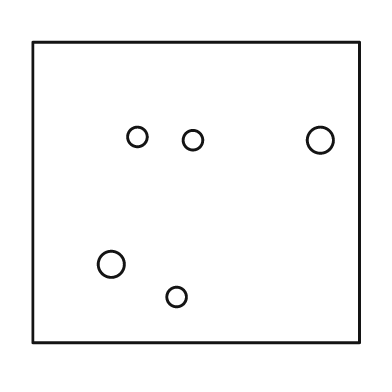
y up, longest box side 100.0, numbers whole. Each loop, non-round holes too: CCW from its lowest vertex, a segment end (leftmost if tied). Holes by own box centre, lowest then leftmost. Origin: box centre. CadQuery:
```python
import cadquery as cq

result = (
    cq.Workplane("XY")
    .moveTo(-50.0, -46.0)
    .lineTo(50.0, -46.0)
    .lineTo(50.0, 46.0)
    .lineTo(-50.0, 46.0)
    .close()
    .moveTo(-6.0, -32.0)
    .circle(3.0)
    .moveTo(-26.0, -22.0)
    .circle(4.0)
    .moveTo(-1.0, 16.0)
    .circle(3.0)
    .moveTo(38.0, 16.0)
    .circle(4.0)
    .moveTo(-18.0, 17.0)
    .circle(3.0)
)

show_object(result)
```